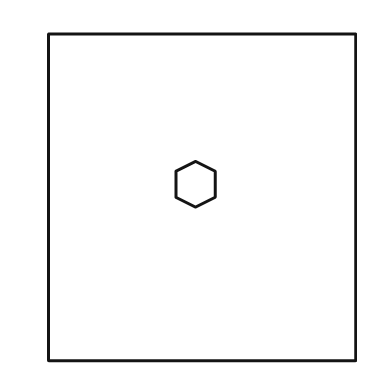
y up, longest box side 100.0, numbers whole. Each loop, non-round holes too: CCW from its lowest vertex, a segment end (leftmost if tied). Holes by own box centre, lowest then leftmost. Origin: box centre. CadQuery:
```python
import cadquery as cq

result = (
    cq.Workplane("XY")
    .moveTo(-47.0, -50.0)
    .lineTo(47.0, -50.0)
    .lineTo(47.0, 50.0)
    .lineTo(-47.0, 50.0)
    .close()
    .moveTo(-2.0, -3.0)
    .lineTo(4.0, 0.0)
    .lineTo(4.0, 8.0)
    .lineTo(-2.0, 11.0)
    .lineTo(-8.0, 8.0)
    .lineTo(-8.0, 0.0)
    .close()
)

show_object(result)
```